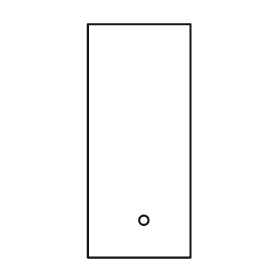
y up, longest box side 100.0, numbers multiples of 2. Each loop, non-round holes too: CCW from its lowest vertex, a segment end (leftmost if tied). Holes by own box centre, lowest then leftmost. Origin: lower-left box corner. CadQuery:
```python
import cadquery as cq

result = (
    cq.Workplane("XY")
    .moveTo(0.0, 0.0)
    .lineTo(44.0, 0.0)
    .lineTo(44.0, 100.0)
    .lineTo(0.0, 100.0)
    .close()
    .moveTo(24.0, 16.0)
    .circle(2.0)
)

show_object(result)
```